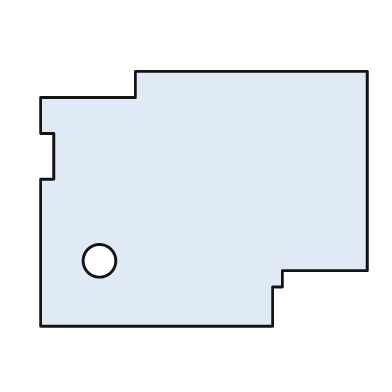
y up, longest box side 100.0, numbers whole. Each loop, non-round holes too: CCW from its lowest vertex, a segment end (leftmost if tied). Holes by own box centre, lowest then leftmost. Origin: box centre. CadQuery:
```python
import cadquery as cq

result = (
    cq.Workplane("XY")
    .moveTo(-50.0, -39.0)
    .lineTo(21.0, -39.0)
    .lineTo(21.0, -27.0)
    .lineTo(24.0, -27.0)
    .lineTo(24.0, -22.0)
    .lineTo(50.0, -22.0)
    .lineTo(50.0, 39.0)
    .lineTo(-21.0, 39.0)
    .lineTo(-21.0, 31.0)
    .lineTo(-50.0, 31.0)
    .lineTo(-50.0, 20.0)
    .lineTo(-46.0, 20.0)
    .lineTo(-46.0, 6.0)
    .lineTo(-50.0, 6.0)
    .close()
    .moveTo(-32.0, -19.0)
    .circle(5.0)
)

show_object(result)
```